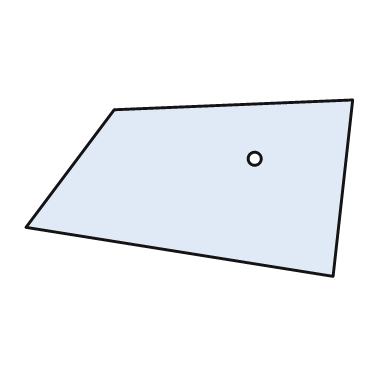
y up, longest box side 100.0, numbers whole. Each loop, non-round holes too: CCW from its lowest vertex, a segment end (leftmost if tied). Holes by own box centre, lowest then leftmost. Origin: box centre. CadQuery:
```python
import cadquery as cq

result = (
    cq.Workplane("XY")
    .moveTo(44.0, -27.0)
    .lineTo(50.0, 27.0)
    .lineTo(-23.0, 24.0)
    .lineTo(-50.0, -12.0)
    .close()
    .moveTo(20.0, 9.0)
    .circle(2.0)
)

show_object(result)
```